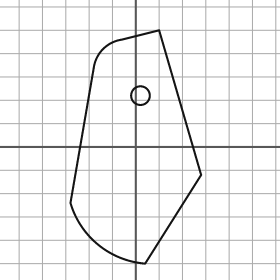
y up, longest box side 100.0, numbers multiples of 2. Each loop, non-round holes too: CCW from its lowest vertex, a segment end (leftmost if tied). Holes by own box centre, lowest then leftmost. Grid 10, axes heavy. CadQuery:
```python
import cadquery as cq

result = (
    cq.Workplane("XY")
    .moveTo(4.0, -50.0)
    .lineTo(28.0, -12.0)
    .lineTo(10.0, 50.0)
    .lineTo(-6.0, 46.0)
    .threePointArc((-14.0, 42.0), (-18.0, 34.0))
    .lineTo(-28.0, -24.0)
    .threePointArc((-16.0, -42.0), (4.0, -50.0))
    .close()
    .moveTo(2.0, 22.0)
    .circle(4.0)
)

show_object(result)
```